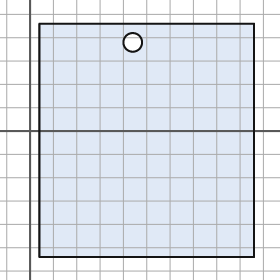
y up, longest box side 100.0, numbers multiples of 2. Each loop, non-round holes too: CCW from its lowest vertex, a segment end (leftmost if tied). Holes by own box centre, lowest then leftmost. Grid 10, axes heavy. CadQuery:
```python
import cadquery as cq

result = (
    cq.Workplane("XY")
    .moveTo(4.0, -54.0)
    .lineTo(96.0, -54.0)
    .lineTo(96.0, 46.0)
    .lineTo(4.0, 46.0)
    .close()
    .moveTo(44.0, 38.0)
    .circle(4.0)
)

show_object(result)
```